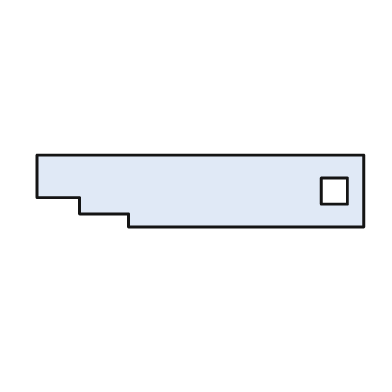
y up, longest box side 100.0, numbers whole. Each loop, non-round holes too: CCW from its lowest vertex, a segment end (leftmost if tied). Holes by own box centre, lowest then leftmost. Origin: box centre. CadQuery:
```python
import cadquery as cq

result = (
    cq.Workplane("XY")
    .moveTo(-22.0, -11.0)
    .lineTo(50.0, -11.0)
    .lineTo(50.0, 11.0)
    .lineTo(-50.0, 11.0)
    .lineTo(-50.0, -2.0)
    .lineTo(-37.0, -2.0)
    .lineTo(-37.0, -7.0)
    .lineTo(-22.0, -7.0)
    .close()
    .moveTo(37.0, -4.0)
    .lineTo(45.0, -4.0)
    .lineTo(45.0, 4.0)
    .lineTo(37.0, 4.0)
    .close()
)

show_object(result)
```